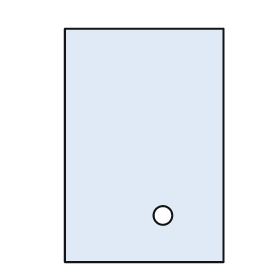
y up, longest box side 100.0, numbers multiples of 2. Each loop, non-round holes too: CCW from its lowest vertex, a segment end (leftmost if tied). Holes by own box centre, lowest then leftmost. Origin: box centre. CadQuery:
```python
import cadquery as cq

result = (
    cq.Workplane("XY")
    .moveTo(-34.0, -50.0)
    .lineTo(34.0, -50.0)
    .lineTo(34.0, 50.0)
    .lineTo(-34.0, 50.0)
    .close()
    .moveTo(8.0, -30.0)
    .circle(4.0)
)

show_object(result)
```